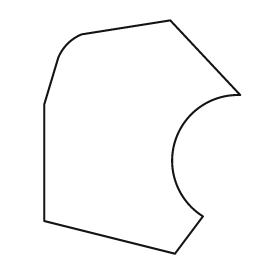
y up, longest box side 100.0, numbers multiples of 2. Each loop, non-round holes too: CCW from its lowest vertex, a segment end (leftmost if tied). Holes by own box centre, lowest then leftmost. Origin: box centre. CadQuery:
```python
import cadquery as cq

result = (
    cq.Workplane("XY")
    .moveTo(14.0, -50.0)
    .lineTo(26.0, -34.0)
    .threePointArc((14.0, -2.0), (42.0, 18.0))
    .lineTo(12.0, 50.0)
    .lineTo(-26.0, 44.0)
    .threePointArc((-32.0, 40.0), (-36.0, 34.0))
    .lineTo(-42.0, 14.0)
    .lineTo(-42.0, -36.0)
    .close()
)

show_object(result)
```